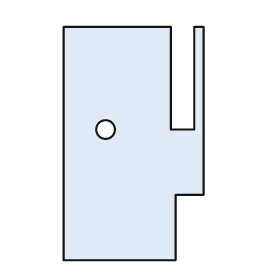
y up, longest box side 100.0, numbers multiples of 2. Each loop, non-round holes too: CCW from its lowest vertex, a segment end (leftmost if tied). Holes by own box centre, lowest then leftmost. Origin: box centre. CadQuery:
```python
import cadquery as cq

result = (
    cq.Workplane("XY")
    .moveTo(-30.0, -50.0)
    .lineTo(18.0, -50.0)
    .lineTo(18.0, -22.0)
    .lineTo(30.0, -22.0)
    .lineTo(30.0, 50.0)
    .lineTo(26.0, 50.0)
    .lineTo(26.0, 6.0)
    .lineTo(16.0, 6.0)
    .lineTo(16.0, 50.0)
    .lineTo(-30.0, 50.0)
    .close()
    .moveTo(-12.0, 6.0)
    .circle(4.0)
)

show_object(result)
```